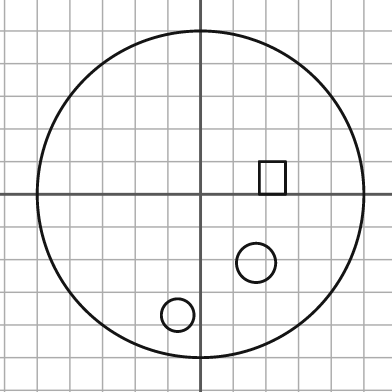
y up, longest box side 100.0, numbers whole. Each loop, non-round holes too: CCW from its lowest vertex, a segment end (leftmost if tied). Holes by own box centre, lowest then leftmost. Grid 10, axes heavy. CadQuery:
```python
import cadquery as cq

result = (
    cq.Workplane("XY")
    .moveTo(0.0, 0.0)
    .circle(50.0)
    .moveTo(-7.0, -37.0)
    .circle(5.0)
    .moveTo(17.0, -21.0)
    .circle(6.0)
    .moveTo(18.0, 0.0)
    .lineTo(26.0, 0.0)
    .lineTo(26.0, 10.0)
    .lineTo(18.0, 10.0)
    .close()
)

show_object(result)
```